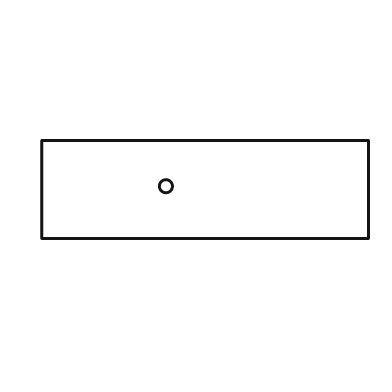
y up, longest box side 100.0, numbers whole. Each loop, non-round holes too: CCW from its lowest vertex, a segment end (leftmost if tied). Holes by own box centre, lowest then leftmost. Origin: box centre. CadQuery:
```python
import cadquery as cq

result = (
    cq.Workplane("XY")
    .moveTo(-50.0, -15.0)
    .lineTo(50.0, -15.0)
    .lineTo(50.0, 15.0)
    .lineTo(-50.0, 15.0)
    .close()
    .moveTo(-12.0, 1.0)
    .circle(2.0)
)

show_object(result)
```